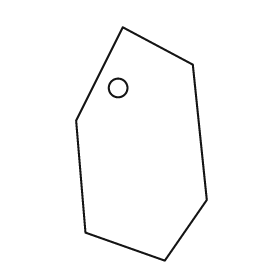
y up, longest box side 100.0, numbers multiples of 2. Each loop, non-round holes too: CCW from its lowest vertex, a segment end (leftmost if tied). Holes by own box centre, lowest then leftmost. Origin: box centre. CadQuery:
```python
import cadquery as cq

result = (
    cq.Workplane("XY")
    .moveTo(10.0, -50.0)
    .lineTo(28.0, -24.0)
    .lineTo(22.0, 34.0)
    .lineTo(-8.0, 50.0)
    .lineTo(-28.0, 10.0)
    .lineTo(-24.0, -38.0)
    .close()
    .moveTo(-10.0, 24.0)
    .circle(4.0)
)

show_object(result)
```